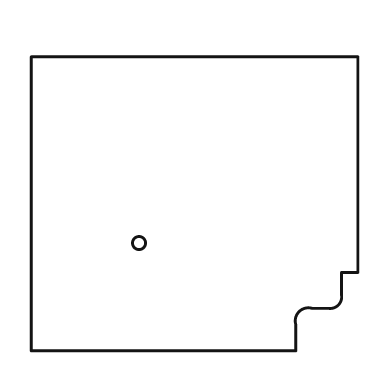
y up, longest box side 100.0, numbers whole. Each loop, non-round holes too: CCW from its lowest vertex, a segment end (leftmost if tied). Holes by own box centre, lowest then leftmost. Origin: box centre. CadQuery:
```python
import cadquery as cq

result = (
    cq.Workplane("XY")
    .moveTo(-50.0, -45.0)
    .lineTo(31.0, -45.0)
    .lineTo(31.0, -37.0)
    .threePointArc((32.0, -33.0), (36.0, -32.0))
    .lineTo(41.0, -32.0)
    .threePointArc((44.0, -31.0), (45.0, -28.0))
    .lineTo(45.0, -21.0)
    .lineTo(50.0, -21.0)
    .lineTo(50.0, 45.0)
    .lineTo(-50.0, 45.0)
    .close()
    .moveTo(-17.0, -12.0)
    .circle(2.0)
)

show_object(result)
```